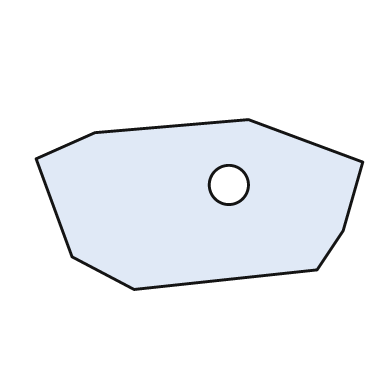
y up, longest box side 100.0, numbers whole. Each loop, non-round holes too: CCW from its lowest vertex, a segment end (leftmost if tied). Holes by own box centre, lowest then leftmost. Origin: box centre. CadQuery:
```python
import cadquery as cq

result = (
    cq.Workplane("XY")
    .moveTo(-20.0, -26.0)
    .lineTo(36.0, -20.0)
    .lineTo(44.0, -8.0)
    .lineTo(50.0, 13.0)
    .lineTo(15.0, 26.0)
    .lineTo(-32.0, 22.0)
    .lineTo(-50.0, 14.0)
    .lineTo(-39.0, -16.0)
    .close()
    .moveTo(9.0, 6.0)
    .circle(6.0)
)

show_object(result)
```